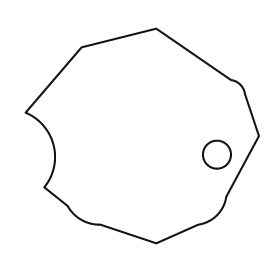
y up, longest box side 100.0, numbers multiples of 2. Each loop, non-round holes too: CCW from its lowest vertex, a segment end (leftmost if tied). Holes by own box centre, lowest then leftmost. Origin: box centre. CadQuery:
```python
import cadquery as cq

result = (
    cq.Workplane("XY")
    .moveTo(6.0, -46.0)
    .lineTo(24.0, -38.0)
    .threePointArc((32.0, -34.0), (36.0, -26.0))
    .lineTo(50.0, 0.0)
    .lineTo(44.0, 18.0)
    .threePointArc((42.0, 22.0), (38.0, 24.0))
    .lineTo(6.0, 46.0)
    .lineTo(-26.0, 38.0)
    .lineTo(-50.0, 10.0)
    .threePointArc((-38.0, -4.0), (-42.0, -22.0))
    .lineTo(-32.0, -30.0)
    .threePointArc((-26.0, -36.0), (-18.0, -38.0))
    .close()
    .moveTo(32.0, -8.0)
    .circle(6.0)
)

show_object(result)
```